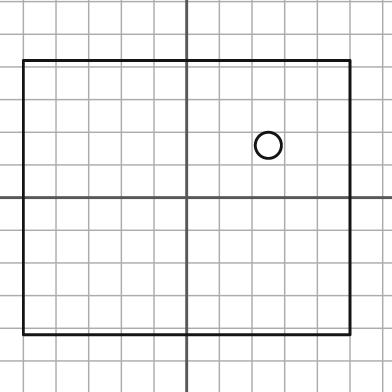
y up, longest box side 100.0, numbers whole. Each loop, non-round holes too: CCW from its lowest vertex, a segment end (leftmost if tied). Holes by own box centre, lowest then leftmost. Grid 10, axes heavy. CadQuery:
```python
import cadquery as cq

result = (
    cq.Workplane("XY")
    .moveTo(-50.0, -42.0)
    .lineTo(50.0, -42.0)
    .lineTo(50.0, 42.0)
    .lineTo(-50.0, 42.0)
    .close()
    .moveTo(25.0, 16.0)
    .circle(4.0)
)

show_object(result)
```